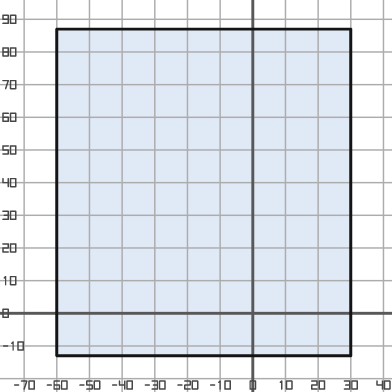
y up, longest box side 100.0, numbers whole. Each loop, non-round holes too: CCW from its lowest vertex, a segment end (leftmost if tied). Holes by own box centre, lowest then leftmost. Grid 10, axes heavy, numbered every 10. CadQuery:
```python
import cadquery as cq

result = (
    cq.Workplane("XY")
    .moveTo(-60.0, -13.0)
    .lineTo(30.0, -13.0)
    .lineTo(30.0, 87.0)
    .lineTo(-60.0, 87.0)
    .close()
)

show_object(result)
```